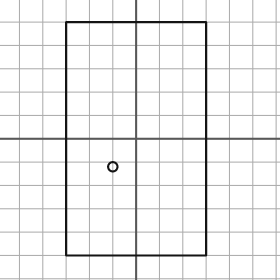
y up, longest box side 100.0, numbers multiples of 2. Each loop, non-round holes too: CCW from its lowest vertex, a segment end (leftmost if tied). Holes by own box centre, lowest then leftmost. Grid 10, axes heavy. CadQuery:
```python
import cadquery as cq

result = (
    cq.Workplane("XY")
    .moveTo(-30.0, -50.0)
    .lineTo(30.0, -50.0)
    .lineTo(30.0, 50.0)
    .lineTo(-30.0, 50.0)
    .close()
    .moveTo(-10.0, -12.0)
    .circle(2.0)
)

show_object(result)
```